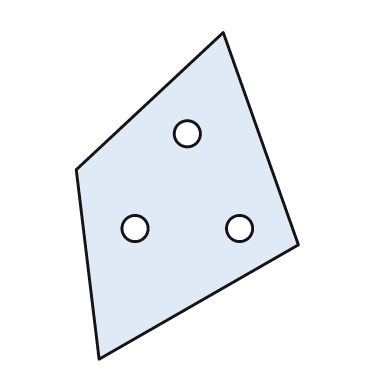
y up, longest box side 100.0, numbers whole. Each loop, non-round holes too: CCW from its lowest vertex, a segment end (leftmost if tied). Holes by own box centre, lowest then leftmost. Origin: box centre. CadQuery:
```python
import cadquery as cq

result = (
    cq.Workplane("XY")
    .moveTo(-27.0, -50.0)
    .lineTo(34.0, -15.0)
    .lineTo(11.0, 50.0)
    .lineTo(-34.0, 8.0)
    .close()
    .moveTo(-16.0, -10.0)
    .circle(4.0)
    .moveTo(16.0, -10.0)
    .circle(4.0)
    .moveTo(0.0, 19.0)
    .circle(4.0)
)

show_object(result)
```